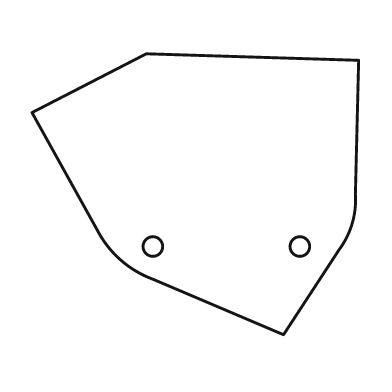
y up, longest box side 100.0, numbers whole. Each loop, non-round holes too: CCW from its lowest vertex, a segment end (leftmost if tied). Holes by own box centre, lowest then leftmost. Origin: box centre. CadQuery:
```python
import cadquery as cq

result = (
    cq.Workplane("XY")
    .moveTo(27.0, -43.0)
    .lineTo(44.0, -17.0)
    .threePointArc((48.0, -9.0), (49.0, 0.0))
    .lineTo(50.0, 41.0)
    .lineTo(-15.0, 43.0)
    .lineTo(-50.0, 25.0)
    .lineTo(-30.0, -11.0)
    .threePointArc((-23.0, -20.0), (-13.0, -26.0))
    .close()
    .moveTo(-13.0, -16.0)
    .circle(3.0)
    .moveTo(32.0, -16.0)
    .circle(3.0)
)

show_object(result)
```